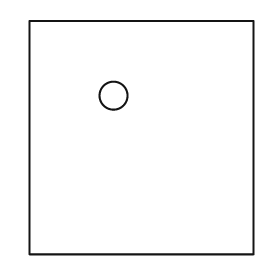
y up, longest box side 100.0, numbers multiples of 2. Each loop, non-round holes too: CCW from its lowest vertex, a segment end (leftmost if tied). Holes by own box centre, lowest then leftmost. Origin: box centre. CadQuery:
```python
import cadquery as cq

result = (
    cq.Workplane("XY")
    .moveTo(-48.0, -50.0)
    .lineTo(48.0, -50.0)
    .lineTo(48.0, 50.0)
    .lineTo(-48.0, 50.0)
    .close()
    .moveTo(-12.0, 18.0)
    .circle(6.0)
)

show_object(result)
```